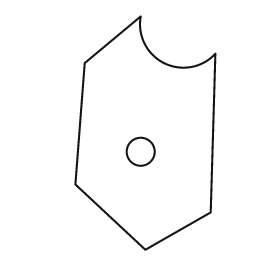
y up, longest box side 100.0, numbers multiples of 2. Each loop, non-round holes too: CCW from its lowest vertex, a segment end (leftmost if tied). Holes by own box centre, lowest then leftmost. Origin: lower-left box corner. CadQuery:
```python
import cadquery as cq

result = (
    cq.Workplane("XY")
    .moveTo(30.0, 0.0)
    .lineTo(58.0, 16.0)
    .lineTo(60.0, 84.0)
    .threePointArc((38.0, 80.0), (28.0, 100.0))
    .lineTo(4.0, 80.0)
    .lineTo(0.0, 28.0)
    .close()
    .moveTo(28.0, 42.0)
    .circle(6.0)
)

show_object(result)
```